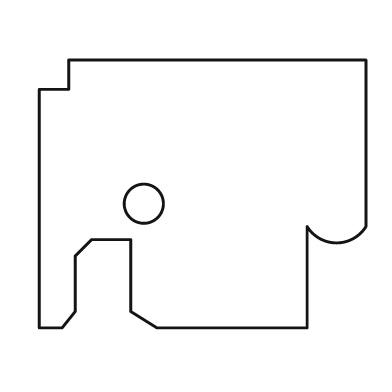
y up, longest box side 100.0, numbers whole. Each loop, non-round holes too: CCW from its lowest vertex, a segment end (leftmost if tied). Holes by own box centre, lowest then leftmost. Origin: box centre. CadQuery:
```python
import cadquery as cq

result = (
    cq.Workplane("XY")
    .moveTo(-50.0, -41.0)
    .lineTo(-43.0, -41.0)
    .lineTo(-39.0, -36.0)
    .lineTo(-39.0, -19.0)
    .lineTo(-34.0, -14.0)
    .lineTo(-22.0, -14.0)
    .lineTo(-22.0, -36.0)
    .lineTo(-14.0, -41.0)
    .lineTo(32.0, -41.0)
    .lineTo(32.0, -10.0)
    .threePointArc((41.0, -15.0), (50.0, -10.0))
    .lineTo(50.0, 41.0)
    .lineTo(-41.0, 41.0)
    .lineTo(-41.0, 32.0)
    .lineTo(-50.0, 32.0)
    .close()
    .moveTo(-18.0, -3.0)
    .circle(6.0)
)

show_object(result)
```